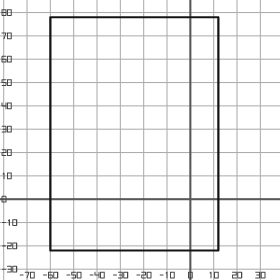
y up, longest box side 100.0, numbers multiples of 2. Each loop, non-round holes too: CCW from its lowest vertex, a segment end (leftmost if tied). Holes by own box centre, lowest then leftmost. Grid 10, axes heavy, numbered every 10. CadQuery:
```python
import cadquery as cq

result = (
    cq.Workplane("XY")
    .moveTo(-60.0, -22.0)
    .lineTo(12.0, -22.0)
    .lineTo(12.0, 78.0)
    .lineTo(-60.0, 78.0)
    .close()
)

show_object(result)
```